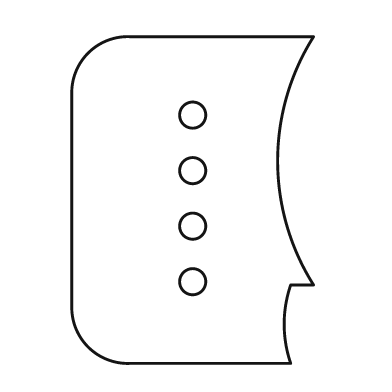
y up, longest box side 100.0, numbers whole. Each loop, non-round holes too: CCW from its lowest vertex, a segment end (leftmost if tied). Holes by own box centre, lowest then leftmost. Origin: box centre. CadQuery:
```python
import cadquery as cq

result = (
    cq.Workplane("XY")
    .moveTo(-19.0, -50.0)
    .lineTo(30.0, -50.0)
    .threePointArc((28.0, -38.0), (30.0, -26.0))
    .lineTo(37.0, -26.0)
    .threePointArc((26.0, 12.0), (37.0, 50.0))
    .lineTo(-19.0, 50.0)
    .threePointArc((-32.0, 45.0), (-37.0, 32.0))
    .lineTo(-37.0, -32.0)
    .threePointArc((-32.0, -45.0), (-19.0, -50.0))
    .close()
    .moveTo(0.0, -25.0)
    .circle(4.0)
    .moveTo(0.0, -8.0)
    .circle(4.0)
    .moveTo(0.0, 9.0)
    .circle(4.0)
    .moveTo(0.0, 26.0)
    .circle(4.0)
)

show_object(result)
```